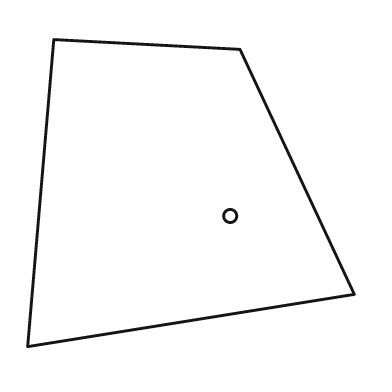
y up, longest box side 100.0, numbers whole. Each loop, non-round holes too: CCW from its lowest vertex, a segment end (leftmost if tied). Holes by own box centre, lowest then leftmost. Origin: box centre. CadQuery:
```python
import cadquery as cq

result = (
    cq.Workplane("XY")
    .moveTo(-50.0, -47.0)
    .lineTo(50.0, -31.0)
    .lineTo(15.0, 44.0)
    .lineTo(-42.0, 47.0)
    .close()
    .moveTo(12.0, -7.0)
    .circle(2.0)
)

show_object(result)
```